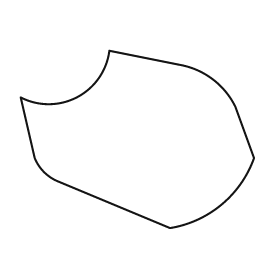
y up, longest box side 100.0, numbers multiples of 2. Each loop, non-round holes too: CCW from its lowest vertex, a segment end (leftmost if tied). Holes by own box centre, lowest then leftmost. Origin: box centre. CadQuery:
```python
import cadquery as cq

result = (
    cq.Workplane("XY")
    .moveTo(14.0, -38.0)
    .threePointArc((36.0, -28.0), (50.0, -8.0))
    .lineTo(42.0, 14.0)
    .threePointArc((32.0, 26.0), (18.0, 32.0))
    .lineTo(-12.0, 38.0)
    .threePointArc((-26.0, 18.0), (-50.0, 18.0))
    .lineTo(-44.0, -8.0)
    .threePointArc((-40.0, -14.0), (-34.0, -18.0))
    .close()
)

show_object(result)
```